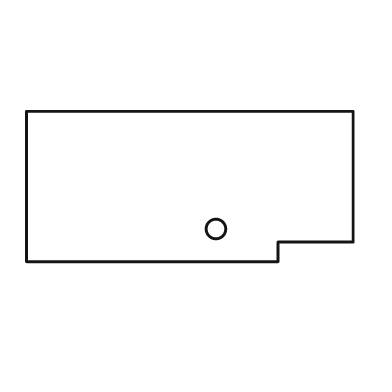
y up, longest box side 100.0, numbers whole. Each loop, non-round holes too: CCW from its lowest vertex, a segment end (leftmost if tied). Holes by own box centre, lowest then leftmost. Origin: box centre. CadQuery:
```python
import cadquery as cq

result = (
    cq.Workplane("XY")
    .moveTo(-50.0, -23.0)
    .lineTo(27.0, -23.0)
    .lineTo(27.0, -17.0)
    .lineTo(50.0, -17.0)
    .lineTo(50.0, 23.0)
    .lineTo(-50.0, 23.0)
    .close()
    .moveTo(8.0, -13.0)
    .circle(3.0)
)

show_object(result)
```